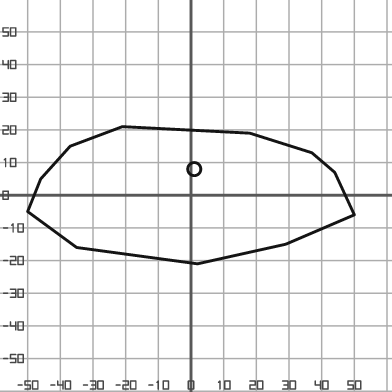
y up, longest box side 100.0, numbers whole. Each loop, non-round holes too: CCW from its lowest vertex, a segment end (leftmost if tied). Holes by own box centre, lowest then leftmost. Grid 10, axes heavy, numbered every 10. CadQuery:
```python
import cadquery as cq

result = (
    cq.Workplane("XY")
    .moveTo(2.0, -21.0)
    .lineTo(29.0, -15.0)
    .lineTo(50.0, -6.0)
    .lineTo(44.0, 7.0)
    .lineTo(37.0, 13.0)
    .lineTo(18.0, 19.0)
    .lineTo(-21.0, 21.0)
    .lineTo(-37.0, 15.0)
    .lineTo(-46.0, 5.0)
    .lineTo(-50.0, -5.0)
    .lineTo(-35.0, -16.0)
    .close()
    .moveTo(1.0, 8.0)
    .circle(2.0)
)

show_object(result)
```